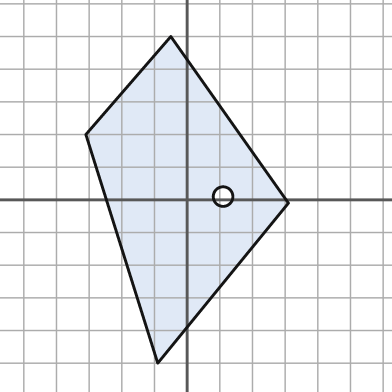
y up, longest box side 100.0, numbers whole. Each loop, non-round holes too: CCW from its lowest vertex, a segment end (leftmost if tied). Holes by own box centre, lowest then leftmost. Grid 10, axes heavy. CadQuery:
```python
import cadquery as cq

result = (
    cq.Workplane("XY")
    .moveTo(-9.0, -50.0)
    .lineTo(31.0, -1.0)
    .lineTo(-5.0, 50.0)
    .lineTo(-31.0, 20.0)
    .close()
    .moveTo(11.0, 1.0)
    .circle(3.0)
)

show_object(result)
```